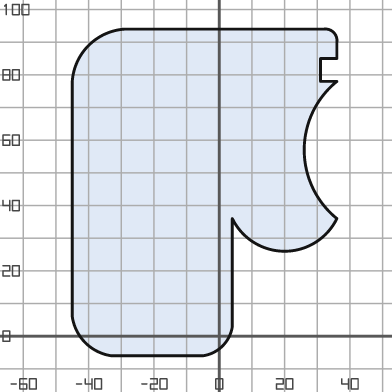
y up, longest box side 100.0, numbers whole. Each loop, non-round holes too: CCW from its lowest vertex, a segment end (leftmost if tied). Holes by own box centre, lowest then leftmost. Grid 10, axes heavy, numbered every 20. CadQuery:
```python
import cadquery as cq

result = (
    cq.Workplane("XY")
    .moveTo(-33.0, -6.0)
    .lineTo(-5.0, -6.0)
    .threePointArc((1.0, -3.0), (4.0, 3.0))
    .lineTo(4.0, 36.0)
    .threePointArc((20.0, 26.0), (36.0, 36.0))
    .threePointArc((26.0, 57.0), (36.0, 78.0))
    .lineTo(31.0, 78.0)
    .lineTo(31.0, 85.0)
    .lineTo(36.0, 85.0)
    .lineTo(36.0, 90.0)
    .threePointArc((35.0, 93.0), (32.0, 94.0))
    .lineTo(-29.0, 94.0)
    .threePointArc((-40.0, 89.0), (-45.0, 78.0))
    .lineTo(-45.0, 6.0)
    .threePointArc((-41.0, -2.0), (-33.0, -6.0))
    .close()
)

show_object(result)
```